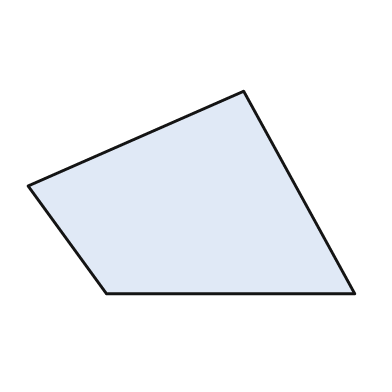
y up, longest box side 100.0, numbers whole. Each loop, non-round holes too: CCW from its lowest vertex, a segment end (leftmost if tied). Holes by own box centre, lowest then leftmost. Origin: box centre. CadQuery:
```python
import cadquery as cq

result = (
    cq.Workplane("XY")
    .moveTo(-26.0, -31.0)
    .lineTo(50.0, -31.0)
    .lineTo(16.0, 31.0)
    .lineTo(-50.0, 2.0)
    .close()
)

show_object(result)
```